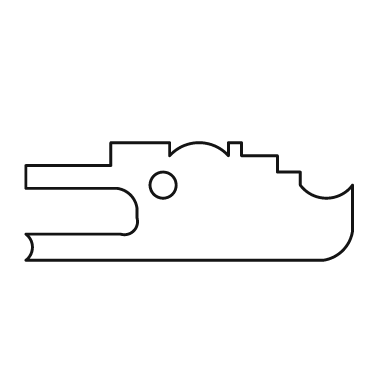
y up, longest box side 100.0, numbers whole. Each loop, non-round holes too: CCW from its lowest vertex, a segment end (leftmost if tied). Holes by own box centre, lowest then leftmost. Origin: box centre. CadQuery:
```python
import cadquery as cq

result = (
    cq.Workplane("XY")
    .moveTo(-50.0, -18.0)
    .lineTo(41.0, -18.0)
    .threePointArc((47.0, -15.0), (50.0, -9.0))
    .lineTo(50.0, 5.0)
    .threePointArc((42.0, 1.0), (34.0, 5.0))
    .lineTo(34.0, 9.0)
    .lineTo(27.0, 9.0)
    .lineTo(27.0, 14.0)
    .lineTo(16.0, 14.0)
    .lineTo(16.0, 18.0)
    .lineTo(12.0, 18.0)
    .lineTo(12.0, 14.0)
    .threePointArc((3.0, 18.0), (-6.0, 14.0))
    .lineTo(-6.0, 18.0)
    .lineTo(-24.0, 18.0)
    .lineTo(-24.0, 11.0)
    .lineTo(-50.0, 11.0)
    .lineTo(-50.0, 4.0)
    .lineTo(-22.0, 4.0)
    .threePointArc((-18.0, 2.0), (-16.0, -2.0))
    .lineTo(-16.0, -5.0)
    .threePointArc((-17.0, -9.0), (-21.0, -10.0))
    .lineTo(-50.0, -10.0)
    .threePointArc((-48.0, -14.0), (-50.0, -18.0))
    .close()
    .moveTo(-8.0, 5.0)
    .circle(4.0)
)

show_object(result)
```